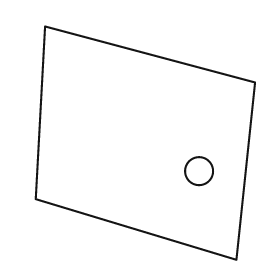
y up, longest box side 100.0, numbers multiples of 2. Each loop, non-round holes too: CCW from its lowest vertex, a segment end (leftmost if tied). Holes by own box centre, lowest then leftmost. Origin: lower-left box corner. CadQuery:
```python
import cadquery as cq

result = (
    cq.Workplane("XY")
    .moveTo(86.0, 0.0)
    .lineTo(94.0, 76.0)
    .lineTo(4.0, 100.0)
    .lineTo(0.0, 26.0)
    .close()
    .moveTo(70.0, 38.0)
    .circle(6.0)
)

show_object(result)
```